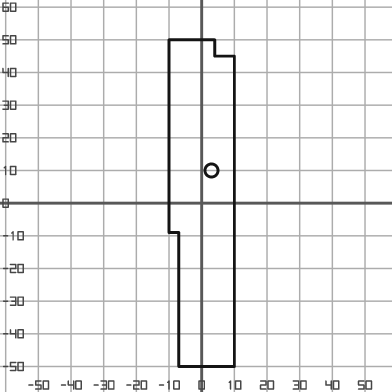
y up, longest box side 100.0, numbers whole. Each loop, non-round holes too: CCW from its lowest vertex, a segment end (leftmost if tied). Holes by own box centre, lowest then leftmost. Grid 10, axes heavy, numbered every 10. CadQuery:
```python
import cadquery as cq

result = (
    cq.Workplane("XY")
    .moveTo(-7.0, -50.0)
    .lineTo(10.0, -50.0)
    .lineTo(10.0, 45.0)
    .lineTo(4.0, 45.0)
    .lineTo(4.0, 50.0)
    .lineTo(-10.0, 50.0)
    .lineTo(-10.0, -9.0)
    .lineTo(-7.0, -9.0)
    .close()
    .moveTo(3.0, 10.0)
    .circle(2.0)
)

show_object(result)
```